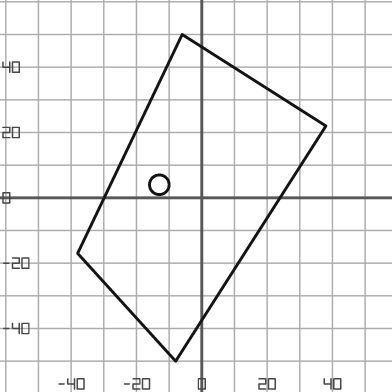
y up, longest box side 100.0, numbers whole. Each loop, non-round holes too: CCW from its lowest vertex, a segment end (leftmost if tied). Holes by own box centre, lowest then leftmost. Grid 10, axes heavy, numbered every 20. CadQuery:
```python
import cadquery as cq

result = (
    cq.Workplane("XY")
    .moveTo(-8.0, -50.0)
    .lineTo(38.0, 22.0)
    .lineTo(-6.0, 50.0)
    .lineTo(-38.0, -17.0)
    .close()
    .moveTo(-13.0, 4.0)
    .circle(3.0)
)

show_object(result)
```